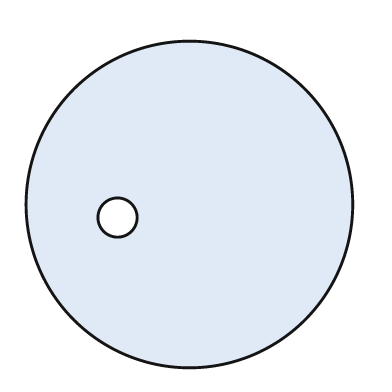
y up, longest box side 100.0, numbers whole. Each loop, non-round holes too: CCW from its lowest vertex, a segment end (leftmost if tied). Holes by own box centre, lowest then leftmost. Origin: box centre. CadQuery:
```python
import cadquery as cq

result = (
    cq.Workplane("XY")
    .moveTo(0.0, 0.0)
    .circle(50.0)
    .moveTo(-22.0, -4.0)
    .circle(6.0)
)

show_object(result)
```